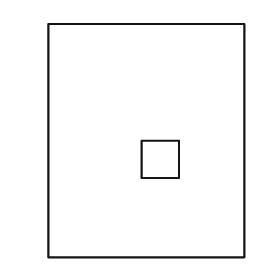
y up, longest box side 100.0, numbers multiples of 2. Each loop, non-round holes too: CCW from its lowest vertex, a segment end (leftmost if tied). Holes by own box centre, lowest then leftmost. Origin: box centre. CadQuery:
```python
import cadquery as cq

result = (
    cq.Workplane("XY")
    .moveTo(-42.0, -50.0)
    .lineTo(42.0, -50.0)
    .lineTo(42.0, 50.0)
    .lineTo(-42.0, 50.0)
    .close()
    .moveTo(-2.0, -16.0)
    .lineTo(14.0, -16.0)
    .lineTo(14.0, 0.0)
    .lineTo(-2.0, 0.0)
    .close()
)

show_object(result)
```